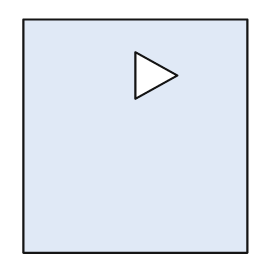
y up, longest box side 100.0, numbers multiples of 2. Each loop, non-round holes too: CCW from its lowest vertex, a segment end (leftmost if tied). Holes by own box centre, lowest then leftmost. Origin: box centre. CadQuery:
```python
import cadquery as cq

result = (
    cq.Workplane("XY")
    .moveTo(-48.0, -50.0)
    .lineTo(48.0, -50.0)
    .lineTo(48.0, 50.0)
    .lineTo(-48.0, 50.0)
    .close()
    .moveTo(0.0, 16.0)
    .lineTo(18.0, 26.0)
    .lineTo(0.0, 36.0)
    .close()
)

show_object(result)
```